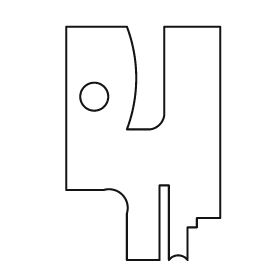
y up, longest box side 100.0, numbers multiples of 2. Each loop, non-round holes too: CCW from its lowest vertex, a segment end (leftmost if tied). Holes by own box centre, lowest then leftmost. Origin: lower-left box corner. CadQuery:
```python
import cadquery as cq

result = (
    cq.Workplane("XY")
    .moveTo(26.0, 0.0)
    .lineTo(40.0, 0.0)
    .lineTo(40.0, 32.0)
    .lineTo(44.0, 32.0)
    .lineTo(44.0, 0.0)
    .threePointArc((48.0, 2.0), (52.0, 0.0))
    .lineTo(52.0, 14.0)
    .lineTo(56.0, 14.0)
    .lineTo(56.0, 18.0)
    .lineTo(66.0, 18.0)
    .lineTo(66.0, 100.0)
    .lineTo(42.0, 100.0)
    .lineTo(42.0, 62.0)
    .threePointArc((40.0, 58.0), (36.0, 56.0))
    .lineTo(26.0, 56.0)
    .threePointArc((30.0, 78.0), (26.0, 100.0))
    .lineTo(0.0, 100.0)
    .lineTo(0.0, 30.0)
    .lineTo(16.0, 30.0)
    .threePointArc((24.0, 28.0), (26.0, 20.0))
    .close()
    .moveTo(12.0, 70.0)
    .circle(6.0)
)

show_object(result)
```